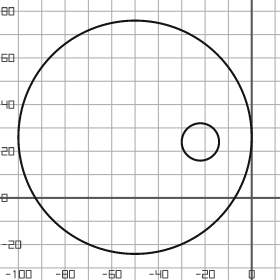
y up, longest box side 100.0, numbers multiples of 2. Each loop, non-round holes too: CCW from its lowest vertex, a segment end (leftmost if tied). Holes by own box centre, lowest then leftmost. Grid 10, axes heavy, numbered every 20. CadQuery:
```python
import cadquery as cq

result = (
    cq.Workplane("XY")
    .moveTo(-50.0, 26.0)
    .circle(50.0)
    .moveTo(-22.0, 24.0)
    .circle(8.0)
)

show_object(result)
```